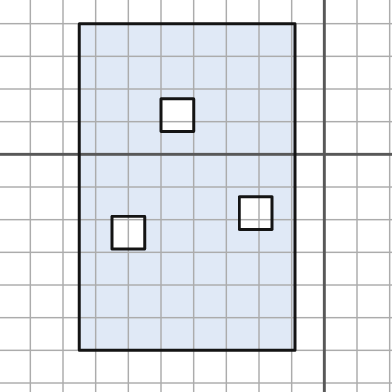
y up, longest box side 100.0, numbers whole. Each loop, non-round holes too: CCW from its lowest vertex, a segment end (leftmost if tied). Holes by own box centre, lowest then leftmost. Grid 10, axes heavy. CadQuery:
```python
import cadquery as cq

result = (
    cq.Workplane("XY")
    .moveTo(-75.0, -60.0)
    .lineTo(-9.0, -60.0)
    .lineTo(-9.0, 40.0)
    .lineTo(-75.0, 40.0)
    .close()
    .moveTo(-65.0, -29.0)
    .lineTo(-55.0, -29.0)
    .lineTo(-55.0, -19.0)
    .lineTo(-65.0, -19.0)
    .close()
    .moveTo(-26.0, -23.0)
    .lineTo(-16.0, -23.0)
    .lineTo(-16.0, -13.0)
    .lineTo(-26.0, -13.0)
    .close()
    .moveTo(-50.0, 7.0)
    .lineTo(-40.0, 7.0)
    .lineTo(-40.0, 17.0)
    .lineTo(-50.0, 17.0)
    .close()
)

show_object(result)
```